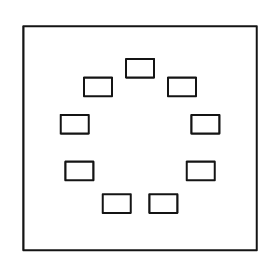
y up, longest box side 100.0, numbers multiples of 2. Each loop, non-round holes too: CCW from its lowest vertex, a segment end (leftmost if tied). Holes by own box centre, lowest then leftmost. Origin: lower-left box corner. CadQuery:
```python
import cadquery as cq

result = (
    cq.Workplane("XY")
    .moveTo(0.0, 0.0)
    .lineTo(100.0, 0.0)
    .lineTo(100.0, 96.0)
    .lineTo(0.0, 96.0)
    .close()
    .moveTo(34.0, 16.0)
    .lineTo(46.0, 16.0)
    .lineTo(46.0, 24.0)
    .lineTo(34.0, 24.0)
    .close()
    .moveTo(54.0, 16.0)
    .lineTo(66.0, 16.0)
    .lineTo(66.0, 24.0)
    .lineTo(54.0, 24.0)
    .close()
    .moveTo(18.0, 30.0)
    .lineTo(30.0, 30.0)
    .lineTo(30.0, 38.0)
    .lineTo(18.0, 38.0)
    .close()
    .moveTo(70.0, 30.0)
    .lineTo(82.0, 30.0)
    .lineTo(82.0, 38.0)
    .lineTo(70.0, 38.0)
    .close()
    .moveTo(16.0, 50.0)
    .lineTo(28.0, 50.0)
    .lineTo(28.0, 58.0)
    .lineTo(16.0, 58.0)
    .close()
    .moveTo(72.0, 50.0)
    .lineTo(84.0, 50.0)
    .lineTo(84.0, 58.0)
    .lineTo(72.0, 58.0)
    .close()
    .moveTo(26.0, 66.0)
    .lineTo(38.0, 66.0)
    .lineTo(38.0, 74.0)
    .lineTo(26.0, 74.0)
    .close()
    .moveTo(62.0, 66.0)
    .lineTo(74.0, 66.0)
    .lineTo(74.0, 74.0)
    .lineTo(62.0, 74.0)
    .close()
    .moveTo(44.0, 74.0)
    .lineTo(56.0, 74.0)
    .lineTo(56.0, 82.0)
    .lineTo(44.0, 82.0)
    .close()
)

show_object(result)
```